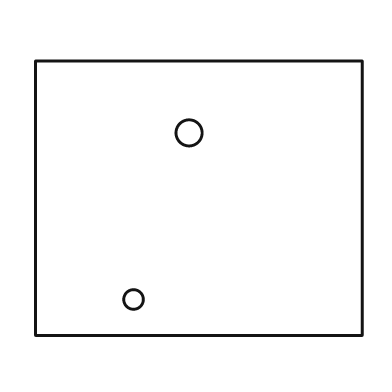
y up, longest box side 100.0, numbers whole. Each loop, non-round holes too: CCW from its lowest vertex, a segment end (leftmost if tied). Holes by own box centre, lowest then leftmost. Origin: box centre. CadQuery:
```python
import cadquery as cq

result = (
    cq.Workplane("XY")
    .moveTo(-50.0, -42.0)
    .lineTo(50.0, -42.0)
    .lineTo(50.0, 42.0)
    .lineTo(-50.0, 42.0)
    .close()
    .moveTo(-20.0, -31.0)
    .circle(3.0)
    .moveTo(-3.0, 20.0)
    .circle(4.0)
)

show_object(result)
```